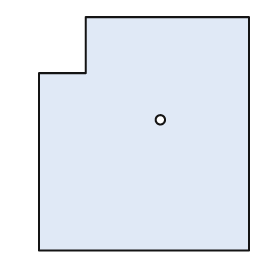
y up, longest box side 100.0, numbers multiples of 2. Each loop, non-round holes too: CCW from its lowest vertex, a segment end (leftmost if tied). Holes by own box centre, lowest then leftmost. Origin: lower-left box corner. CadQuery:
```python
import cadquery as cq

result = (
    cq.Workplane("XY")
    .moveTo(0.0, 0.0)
    .lineTo(90.0, 0.0)
    .lineTo(90.0, 100.0)
    .lineTo(20.0, 100.0)
    .lineTo(20.0, 76.0)
    .lineTo(0.0, 76.0)
    .close()
    .moveTo(52.0, 56.0)
    .circle(2.0)
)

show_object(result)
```